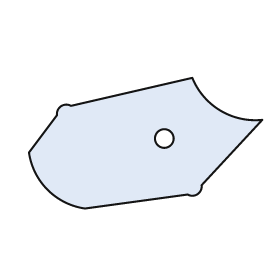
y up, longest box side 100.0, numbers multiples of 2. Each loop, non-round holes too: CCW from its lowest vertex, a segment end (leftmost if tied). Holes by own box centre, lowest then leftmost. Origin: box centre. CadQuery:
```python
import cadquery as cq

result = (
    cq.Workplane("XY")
    .moveTo(-26.0, -28.0)
    .lineTo(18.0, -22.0)
    .threePointArc((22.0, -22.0), (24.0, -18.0))
    .lineTo(50.0, 10.0)
    .threePointArc((32.0, 14.0), (20.0, 28.0))
    .lineTo(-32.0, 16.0)
    .threePointArc((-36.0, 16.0), (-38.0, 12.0))
    .lineTo(-50.0, -4.0)
    .threePointArc((-42.0, -20.0), (-26.0, -28.0))
    .close()
    .moveTo(8.0, 2.0)
    .circle(4.0)
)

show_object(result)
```